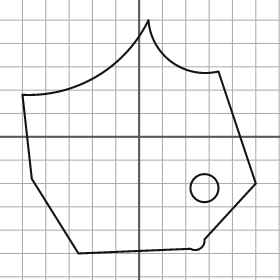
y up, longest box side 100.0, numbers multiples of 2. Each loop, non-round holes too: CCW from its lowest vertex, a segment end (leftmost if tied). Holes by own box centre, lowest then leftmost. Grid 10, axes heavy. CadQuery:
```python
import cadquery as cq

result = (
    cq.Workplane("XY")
    .moveTo(-26.0, -50.0)
    .lineTo(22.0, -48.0)
    .threePointArc((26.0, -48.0), (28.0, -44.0))
    .lineTo(50.0, -20.0)
    .lineTo(34.0, 28.0)
    .threePointArc((14.0, 32.0), (4.0, 50.0))
    .threePointArc((-18.0, 26.0), (-50.0, 18.0))
    .lineTo(-46.0, -18.0)
    .close()
    .moveTo(28.0, -22.0)
    .circle(6.0)
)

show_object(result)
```